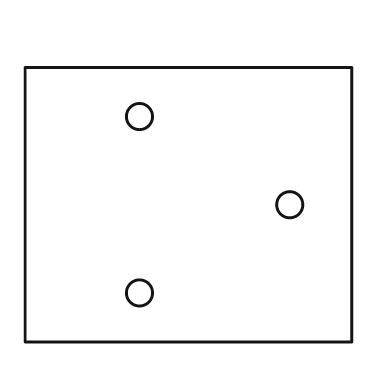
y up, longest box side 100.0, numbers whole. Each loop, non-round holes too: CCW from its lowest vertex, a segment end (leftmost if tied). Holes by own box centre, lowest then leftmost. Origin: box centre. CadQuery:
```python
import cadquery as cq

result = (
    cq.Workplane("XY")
    .moveTo(-50.0, -42.0)
    .lineTo(50.0, -42.0)
    .lineTo(50.0, 42.0)
    .lineTo(-50.0, 42.0)
    .close()
    .moveTo(-15.0, -27.0)
    .circle(4.0)
    .moveTo(31.0, 0.0)
    .circle(4.0)
    .moveTo(-15.0, 27.0)
    .circle(4.0)
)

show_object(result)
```